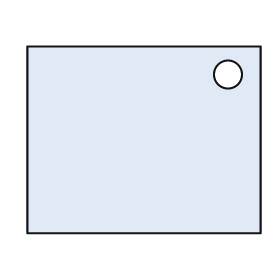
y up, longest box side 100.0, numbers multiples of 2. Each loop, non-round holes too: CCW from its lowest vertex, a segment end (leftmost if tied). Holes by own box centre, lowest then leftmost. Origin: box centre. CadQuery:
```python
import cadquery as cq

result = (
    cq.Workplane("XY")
    .moveTo(-50.0, -40.0)
    .lineTo(50.0, -40.0)
    .lineTo(50.0, 40.0)
    .lineTo(-50.0, 40.0)
    .close()
    .moveTo(36.0, 28.0)
    .circle(6.0)
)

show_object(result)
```